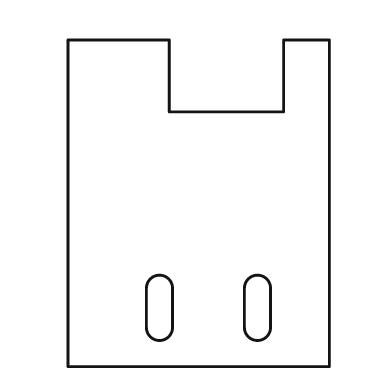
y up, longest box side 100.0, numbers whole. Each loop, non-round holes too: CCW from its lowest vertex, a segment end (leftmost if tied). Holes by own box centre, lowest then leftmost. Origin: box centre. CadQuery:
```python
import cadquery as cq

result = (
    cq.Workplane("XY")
    .moveTo(-40.0, -50.0)
    .lineTo(40.0, -50.0)
    .lineTo(40.0, 50.0)
    .lineTo(26.0, 50.0)
    .lineTo(26.0, 28.0)
    .lineTo(-9.0, 28.0)
    .lineTo(-9.0, 50.0)
    .lineTo(-40.0, 50.0)
    .close()
    .moveTo(-16.0, -38.0)
    .threePointArc((-12.0, -42.0), (-8.0, -38.0))
    .lineTo(-8.0, -26.0)
    .threePointArc((-12.0, -22.0), (-16.0, -26.0))
    .close()
    .moveTo(14.0, -38.0)
    .threePointArc((18.0, -42.0), (22.0, -38.0))
    .lineTo(22.0, -26.0)
    .threePointArc((18.0, -22.0), (14.0, -26.0))
    .close()
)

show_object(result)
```